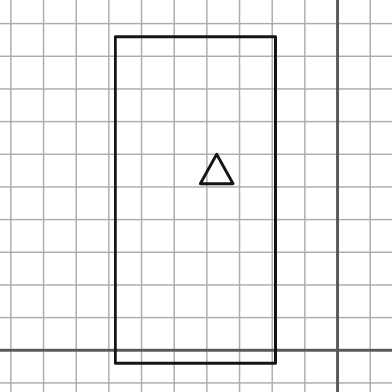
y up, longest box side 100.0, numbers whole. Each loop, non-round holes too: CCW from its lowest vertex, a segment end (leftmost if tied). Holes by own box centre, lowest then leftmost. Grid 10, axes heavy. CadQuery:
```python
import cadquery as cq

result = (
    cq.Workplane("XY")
    .moveTo(-68.0, -4.0)
    .lineTo(-19.0, -4.0)
    .lineTo(-19.0, 96.0)
    .lineTo(-68.0, 96.0)
    .close()
    .moveTo(-42.0, 51.0)
    .lineTo(-32.0, 51.0)
    .lineTo(-37.0, 60.0)
    .close()
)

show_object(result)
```